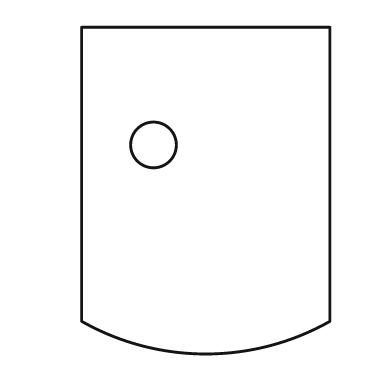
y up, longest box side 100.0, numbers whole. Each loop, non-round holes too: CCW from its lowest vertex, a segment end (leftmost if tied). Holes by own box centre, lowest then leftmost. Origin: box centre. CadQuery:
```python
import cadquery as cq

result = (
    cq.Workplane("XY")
    .moveTo(-38.0, -40.0)
    .threePointArc((0.0, -50.0), (38.0, -40.0))
    .lineTo(38.0, 50.0)
    .lineTo(-38.0, 50.0)
    .close()
    .moveTo(-16.0, 14.0)
    .circle(7.0)
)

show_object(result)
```